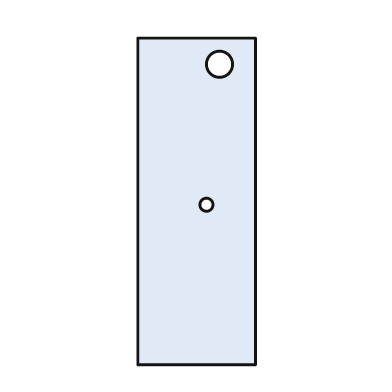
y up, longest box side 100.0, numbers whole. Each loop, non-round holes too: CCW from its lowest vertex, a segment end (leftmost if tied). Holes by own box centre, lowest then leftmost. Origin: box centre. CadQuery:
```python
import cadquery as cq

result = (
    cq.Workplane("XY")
    .moveTo(-18.0, -50.0)
    .lineTo(18.0, -50.0)
    .lineTo(18.0, 50.0)
    .lineTo(-18.0, 50.0)
    .close()
    .moveTo(3.0, -1.0)
    .circle(2.0)
    .moveTo(7.0, 42.0)
    .circle(4.0)
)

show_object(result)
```